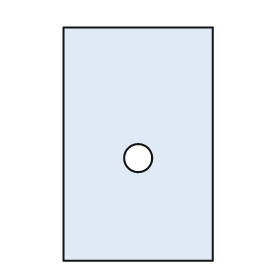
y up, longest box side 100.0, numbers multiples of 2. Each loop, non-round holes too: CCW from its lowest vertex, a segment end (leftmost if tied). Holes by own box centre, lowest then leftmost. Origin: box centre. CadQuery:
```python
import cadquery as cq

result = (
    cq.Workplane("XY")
    .moveTo(-32.0, -50.0)
    .lineTo(32.0, -50.0)
    .lineTo(32.0, 50.0)
    .lineTo(-32.0, 50.0)
    .close()
    .moveTo(0.0, -6.0)
    .circle(6.0)
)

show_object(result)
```